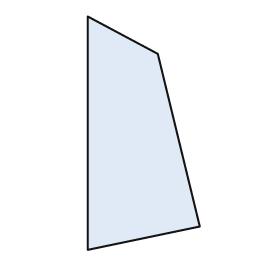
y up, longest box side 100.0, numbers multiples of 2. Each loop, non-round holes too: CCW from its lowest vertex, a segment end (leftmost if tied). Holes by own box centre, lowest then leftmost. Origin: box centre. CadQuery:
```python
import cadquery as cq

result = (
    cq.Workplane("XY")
    .moveTo(-24.0, -50.0)
    .lineTo(24.0, -40.0)
    .lineTo(6.0, 34.0)
    .lineTo(-24.0, 50.0)
    .close()
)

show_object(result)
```